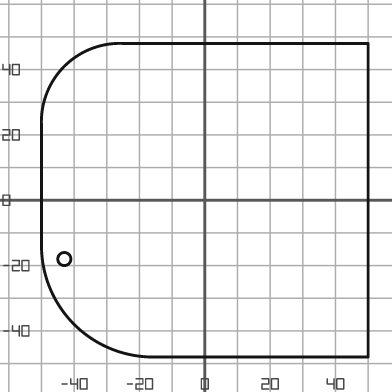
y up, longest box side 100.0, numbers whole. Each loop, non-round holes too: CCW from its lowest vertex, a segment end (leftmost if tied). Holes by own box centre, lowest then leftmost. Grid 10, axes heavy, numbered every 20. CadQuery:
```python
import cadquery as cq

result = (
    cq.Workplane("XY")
    .moveTo(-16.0, -48.0)
    .lineTo(50.0, -48.0)
    .lineTo(50.0, 48.0)
    .lineTo(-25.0, 48.0)
    .threePointArc((-43.0, 41.0), (-50.0, 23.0))
    .lineTo(-50.0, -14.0)
    .threePointArc((-40.0, -38.0), (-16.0, -48.0))
    .close()
    .moveTo(-43.0, -18.0)
    .circle(2.0)
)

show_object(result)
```